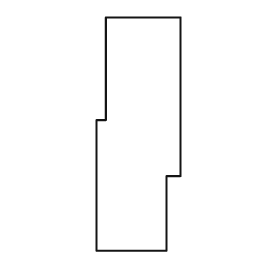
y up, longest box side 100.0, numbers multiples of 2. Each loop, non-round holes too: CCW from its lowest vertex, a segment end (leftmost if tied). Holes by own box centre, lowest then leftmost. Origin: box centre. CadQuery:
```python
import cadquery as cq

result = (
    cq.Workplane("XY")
    .moveTo(-18.0, -50.0)
    .lineTo(12.0, -50.0)
    .lineTo(12.0, -18.0)
    .lineTo(18.0, -18.0)
    .lineTo(18.0, 50.0)
    .lineTo(-14.0, 50.0)
    .lineTo(-14.0, 6.0)
    .lineTo(-18.0, 6.0)
    .close()
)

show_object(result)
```